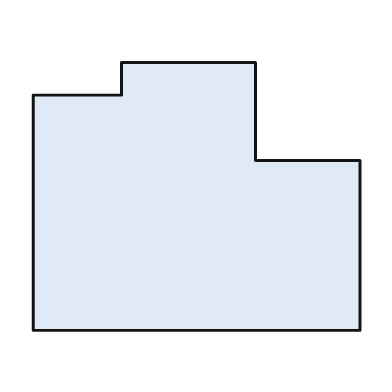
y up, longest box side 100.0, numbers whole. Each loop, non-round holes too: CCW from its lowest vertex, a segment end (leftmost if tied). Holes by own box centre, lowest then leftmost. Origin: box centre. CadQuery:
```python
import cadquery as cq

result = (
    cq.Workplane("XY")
    .moveTo(-50.0, -41.0)
    .lineTo(50.0, -41.0)
    .lineTo(50.0, 11.0)
    .lineTo(18.0, 11.0)
    .lineTo(18.0, 41.0)
    .lineTo(-23.0, 41.0)
    .lineTo(-23.0, 31.0)
    .lineTo(-50.0, 31.0)
    .close()
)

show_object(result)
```